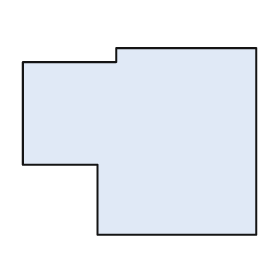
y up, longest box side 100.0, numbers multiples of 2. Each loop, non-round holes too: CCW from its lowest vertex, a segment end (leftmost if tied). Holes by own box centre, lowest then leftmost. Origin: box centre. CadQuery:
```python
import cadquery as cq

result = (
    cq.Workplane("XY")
    .moveTo(-18.0, -40.0)
    .lineTo(50.0, -40.0)
    .lineTo(50.0, 40.0)
    .lineTo(-10.0, 40.0)
    .lineTo(-10.0, 34.0)
    .lineTo(-50.0, 34.0)
    .lineTo(-50.0, -10.0)
    .lineTo(-18.0, -10.0)
    .close()
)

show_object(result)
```